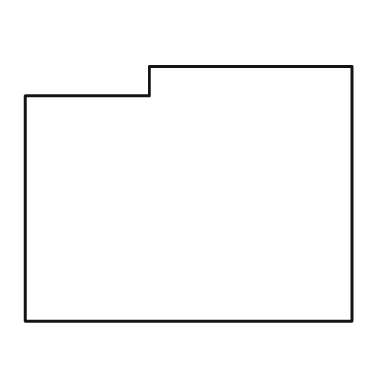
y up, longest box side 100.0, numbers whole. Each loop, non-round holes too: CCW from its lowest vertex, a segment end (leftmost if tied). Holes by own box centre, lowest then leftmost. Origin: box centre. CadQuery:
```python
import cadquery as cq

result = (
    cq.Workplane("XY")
    .moveTo(-50.0, -39.0)
    .lineTo(50.0, -39.0)
    .lineTo(50.0, 39.0)
    .lineTo(-12.0, 39.0)
    .lineTo(-12.0, 30.0)
    .lineTo(-50.0, 30.0)
    .close()
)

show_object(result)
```